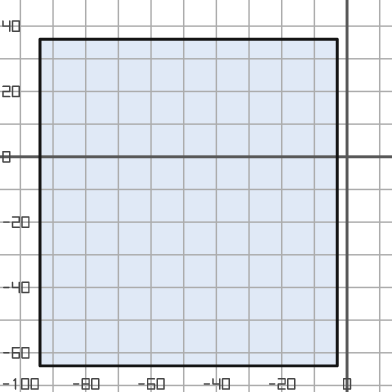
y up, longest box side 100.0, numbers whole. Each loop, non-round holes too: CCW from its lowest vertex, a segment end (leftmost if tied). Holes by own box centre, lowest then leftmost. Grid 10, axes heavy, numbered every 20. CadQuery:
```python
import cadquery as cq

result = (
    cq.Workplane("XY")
    .moveTo(-94.0, -64.0)
    .lineTo(-3.0, -64.0)
    .lineTo(-3.0, 36.0)
    .lineTo(-94.0, 36.0)
    .close()
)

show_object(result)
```